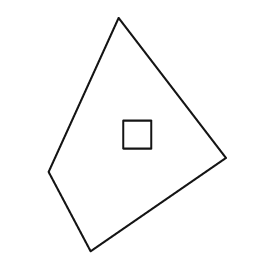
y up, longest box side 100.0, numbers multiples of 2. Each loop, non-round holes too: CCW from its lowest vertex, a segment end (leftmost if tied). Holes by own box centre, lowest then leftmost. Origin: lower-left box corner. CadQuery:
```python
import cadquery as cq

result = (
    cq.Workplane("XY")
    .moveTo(18.0, 0.0)
    .lineTo(76.0, 40.0)
    .lineTo(30.0, 100.0)
    .lineTo(0.0, 34.0)
    .close()
    .moveTo(32.0, 44.0)
    .lineTo(44.0, 44.0)
    .lineTo(44.0, 56.0)
    .lineTo(32.0, 56.0)
    .close()
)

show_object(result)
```